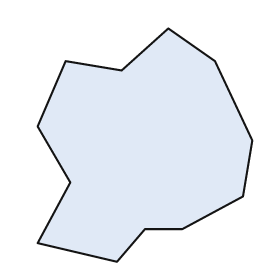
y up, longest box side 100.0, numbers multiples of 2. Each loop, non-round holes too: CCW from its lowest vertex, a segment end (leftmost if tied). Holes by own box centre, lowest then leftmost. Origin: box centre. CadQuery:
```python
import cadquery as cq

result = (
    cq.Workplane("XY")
    .moveTo(-12.0, -50.0)
    .lineTo(0.0, -36.0)
    .lineTo(16.0, -36.0)
    .lineTo(42.0, -22.0)
    .lineTo(46.0, 2.0)
    .lineTo(30.0, 36.0)
    .lineTo(10.0, 50.0)
    .lineTo(-10.0, 32.0)
    .lineTo(-34.0, 36.0)
    .lineTo(-46.0, 8.0)
    .lineTo(-32.0, -16.0)
    .lineTo(-46.0, -42.0)
    .close()
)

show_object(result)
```